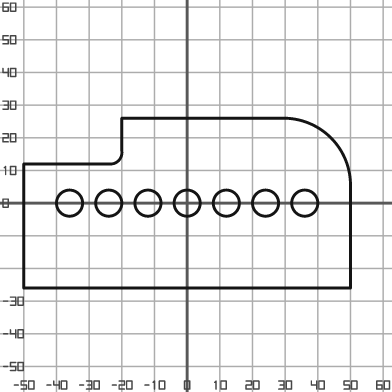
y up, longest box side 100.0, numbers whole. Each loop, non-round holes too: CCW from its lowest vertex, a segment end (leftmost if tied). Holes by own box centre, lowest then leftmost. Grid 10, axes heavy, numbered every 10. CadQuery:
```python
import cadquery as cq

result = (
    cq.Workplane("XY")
    .moveTo(-50.0, -26.0)
    .lineTo(50.0, -26.0)
    .lineTo(50.0, 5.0)
    .threePointArc((44.0, 20.0), (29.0, 26.0))
    .lineTo(-20.0, 26.0)
    .lineTo(-20.0, 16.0)
    .threePointArc((-21.0, 13.0), (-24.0, 12.0))
    .lineTo(-50.0, 12.0)
    .close()
    .moveTo(-36.0, 0.0)
    .circle(4.0)
    .moveTo(-24.0, 0.0)
    .circle(4.0)
    .moveTo(-12.0, 0.0)
    .circle(4.0)
    .moveTo(0.0, 0.0)
    .circle(4.0)
    .moveTo(12.0, 0.0)
    .circle(4.0)
    .moveTo(24.0, 0.0)
    .circle(4.0)
    .moveTo(36.0, 0.0)
    .circle(4.0)
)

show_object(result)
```